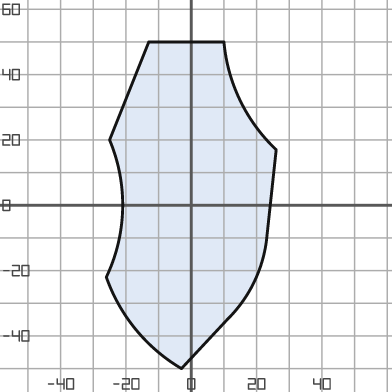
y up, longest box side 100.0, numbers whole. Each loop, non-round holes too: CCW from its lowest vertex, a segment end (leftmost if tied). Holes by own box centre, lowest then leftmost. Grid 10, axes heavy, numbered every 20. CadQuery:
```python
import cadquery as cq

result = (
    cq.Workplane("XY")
    .moveTo(-3.0, -50.0)
    .lineTo(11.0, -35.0)
    .threePointArc((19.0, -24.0), (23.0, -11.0))
    .lineTo(26.0, 17.0)
    .threePointArc((15.0, 32.0), (10.0, 50.0))
    .lineTo(-13.0, 50.0)
    .lineTo(-25.0, 20.0)
    .threePointArc((-21.0, -1.0), (-26.0, -22.0))
    .threePointArc((-17.0, -38.0), (-3.0, -50.0))
    .close()
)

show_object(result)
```